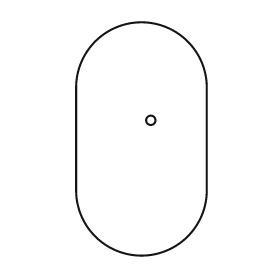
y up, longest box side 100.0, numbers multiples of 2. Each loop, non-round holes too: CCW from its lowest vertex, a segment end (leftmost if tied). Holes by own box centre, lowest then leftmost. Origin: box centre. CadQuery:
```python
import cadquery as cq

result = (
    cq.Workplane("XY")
    .moveTo(-28.0, -22.0)
    .threePointArc((0.0, -50.0), (28.0, -22.0))
    .lineTo(28.0, 22.0)
    .threePointArc((0.0, 50.0), (-28.0, 22.0))
    .close()
    .moveTo(4.0, 8.0)
    .circle(2.0)
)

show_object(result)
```